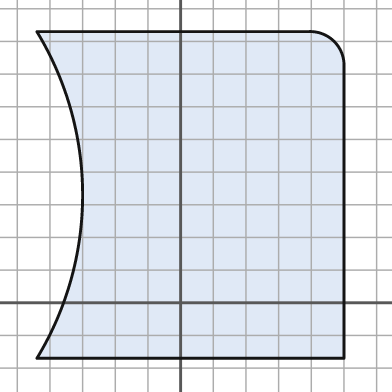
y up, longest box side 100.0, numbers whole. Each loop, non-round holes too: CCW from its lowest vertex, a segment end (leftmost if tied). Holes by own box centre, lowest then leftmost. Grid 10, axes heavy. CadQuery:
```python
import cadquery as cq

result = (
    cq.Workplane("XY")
    .moveTo(-44.0, -17.0)
    .lineTo(50.0, -17.0)
    .lineTo(50.0, 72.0)
    .threePointArc((47.0, 80.0), (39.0, 83.0))
    .lineTo(-44.0, 83.0)
    .threePointArc((-30.0, 33.0), (-44.0, -17.0))
    .close()
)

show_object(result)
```